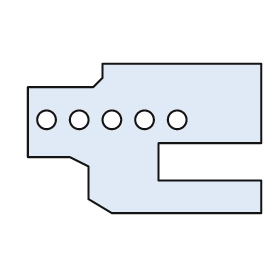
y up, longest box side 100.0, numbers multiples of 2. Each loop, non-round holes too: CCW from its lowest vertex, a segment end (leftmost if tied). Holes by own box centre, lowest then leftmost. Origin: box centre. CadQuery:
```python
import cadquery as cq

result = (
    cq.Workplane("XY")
    .moveTo(-14.0, -32.0)
    .lineTo(50.0, -32.0)
    .lineTo(50.0, -18.0)
    .lineTo(6.0, -18.0)
    .lineTo(6.0, -2.0)
    .lineTo(50.0, -2.0)
    .lineTo(50.0, 32.0)
    .lineTo(-18.0, 32.0)
    .lineTo(-18.0, 26.0)
    .lineTo(-22.0, 22.0)
    .lineTo(-50.0, 22.0)
    .lineTo(-50.0, -8.0)
    .lineTo(-32.0, -8.0)
    .lineTo(-24.0, -12.0)
    .lineTo(-24.0, -26.0)
    .close()
    .moveTo(-42.0, 8.0)
    .circle(4.0)
    .moveTo(-28.0, 8.0)
    .circle(4.0)
    .moveTo(-14.0, 8.0)
    .circle(4.0)
    .moveTo(0.0, 8.0)
    .circle(4.0)
    .moveTo(14.0, 8.0)
    .circle(4.0)
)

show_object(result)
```